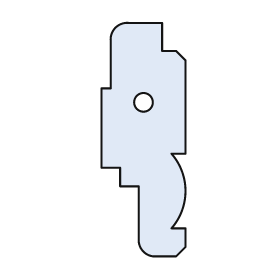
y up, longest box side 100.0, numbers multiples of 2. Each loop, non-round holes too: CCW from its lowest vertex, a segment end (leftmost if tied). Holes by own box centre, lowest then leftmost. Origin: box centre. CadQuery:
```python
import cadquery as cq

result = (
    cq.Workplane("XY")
    .moveTo(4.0, -50.0)
    .lineTo(14.0, -50.0)
    .lineTo(18.0, -46.0)
    .lineTo(18.0, -38.0)
    .lineTo(12.0, -38.0)
    .threePointArc((18.0, -22.0), (12.0, -6.0))
    .lineTo(18.0, -6.0)
    .lineTo(18.0, 34.0)
    .lineTo(14.0, 38.0)
    .lineTo(8.0, 38.0)
    .lineTo(8.0, 50.0)
    .lineTo(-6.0, 50.0)
    .threePointArc((-12.0, 48.0), (-14.0, 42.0))
    .lineTo(-14.0, 22.0)
    .lineTo(-18.0, 22.0)
    .lineTo(-18.0, -12.0)
    .lineTo(-10.0, -12.0)
    .lineTo(-10.0, -20.0)
    .lineTo(-2.0, -20.0)
    .lineTo(-2.0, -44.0)
    .threePointArc((0.0, -48.0), (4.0, -50.0))
    .close()
    .moveTo(0.0, 16.0)
    .circle(4.0)
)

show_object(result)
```